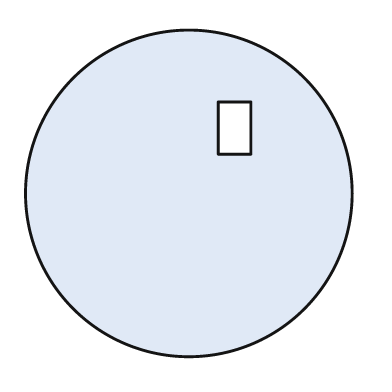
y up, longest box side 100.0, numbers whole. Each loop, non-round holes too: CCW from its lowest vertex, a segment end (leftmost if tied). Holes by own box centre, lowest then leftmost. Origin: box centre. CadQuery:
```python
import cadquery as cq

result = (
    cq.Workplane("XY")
    .moveTo(0.0, 0.0)
    .circle(50.0)
    .moveTo(9.0, 12.0)
    .lineTo(19.0, 12.0)
    .lineTo(19.0, 28.0)
    .lineTo(9.0, 28.0)
    .close()
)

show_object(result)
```